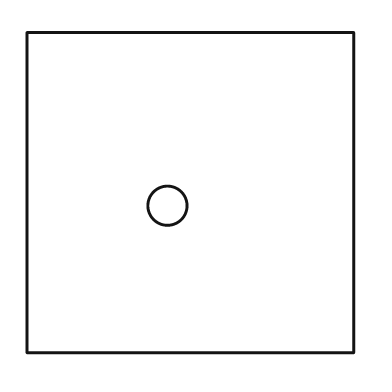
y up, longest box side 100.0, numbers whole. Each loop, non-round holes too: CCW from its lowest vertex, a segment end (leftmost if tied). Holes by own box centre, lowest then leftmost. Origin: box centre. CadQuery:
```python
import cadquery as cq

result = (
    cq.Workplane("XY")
    .moveTo(-50.0, -49.0)
    .lineTo(50.0, -49.0)
    .lineTo(50.0, 49.0)
    .lineTo(-50.0, 49.0)
    .close()
    .moveTo(-7.0, -4.0)
    .circle(6.0)
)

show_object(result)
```